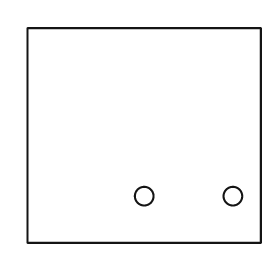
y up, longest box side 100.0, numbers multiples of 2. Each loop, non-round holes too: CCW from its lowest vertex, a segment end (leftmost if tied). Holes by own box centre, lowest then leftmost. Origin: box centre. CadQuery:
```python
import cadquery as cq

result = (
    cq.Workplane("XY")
    .moveTo(-50.0, -46.0)
    .lineTo(50.0, -46.0)
    .lineTo(50.0, 46.0)
    .lineTo(-50.0, 46.0)
    .close()
    .moveTo(0.0, -26.0)
    .circle(4.0)
    .moveTo(38.0, -26.0)
    .circle(4.0)
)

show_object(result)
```